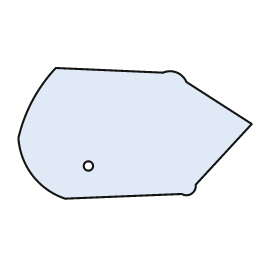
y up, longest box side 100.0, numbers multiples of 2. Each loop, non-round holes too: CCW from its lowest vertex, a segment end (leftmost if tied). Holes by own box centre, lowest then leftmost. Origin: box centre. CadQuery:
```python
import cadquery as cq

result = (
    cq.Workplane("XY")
    .moveTo(-30.0, -28.0)
    .lineTo(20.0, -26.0)
    .threePointArc((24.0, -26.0), (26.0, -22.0))
    .lineTo(50.0, 4.0)
    .lineTo(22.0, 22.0)
    .threePointArc((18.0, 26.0), (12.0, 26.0))
    .lineTo(-34.0, 28.0)
    .threePointArc((-44.0, 14.0), (-50.0, -2.0))
    .threePointArc((-44.0, -18.0), (-30.0, -28.0))
    .close()
    .moveTo(-20.0, -14.0)
    .circle(2.0)
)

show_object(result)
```